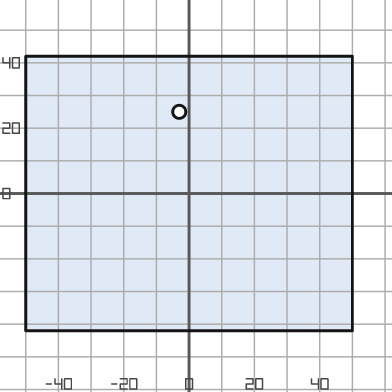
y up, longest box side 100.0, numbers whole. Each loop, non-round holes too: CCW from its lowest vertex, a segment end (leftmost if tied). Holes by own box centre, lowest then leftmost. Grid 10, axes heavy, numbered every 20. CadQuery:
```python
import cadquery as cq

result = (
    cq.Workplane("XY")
    .moveTo(-50.0, -42.0)
    .lineTo(50.0, -42.0)
    .lineTo(50.0, 42.0)
    .lineTo(-50.0, 42.0)
    .close()
    .moveTo(-3.0, 25.0)
    .circle(2.0)
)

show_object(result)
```